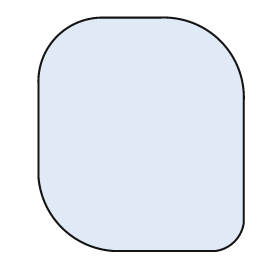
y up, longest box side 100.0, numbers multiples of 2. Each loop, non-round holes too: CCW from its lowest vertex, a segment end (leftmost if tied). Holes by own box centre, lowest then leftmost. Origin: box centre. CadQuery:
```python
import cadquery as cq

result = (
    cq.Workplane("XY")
    .moveTo(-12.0, -50.0)
    .lineTo(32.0, -50.0)
    .threePointArc((40.0, -46.0), (44.0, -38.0))
    .lineTo(44.0, 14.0)
    .threePointArc((34.0, 40.0), (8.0, 50.0))
    .lineTo(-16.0, 50.0)
    .threePointArc((-36.0, 42.0), (-44.0, 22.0))
    .lineTo(-44.0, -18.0)
    .threePointArc((-34.0, -40.0), (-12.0, -50.0))
    .close()
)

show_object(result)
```